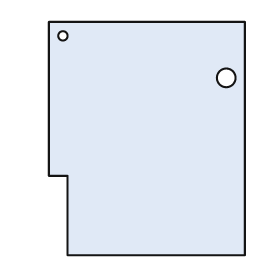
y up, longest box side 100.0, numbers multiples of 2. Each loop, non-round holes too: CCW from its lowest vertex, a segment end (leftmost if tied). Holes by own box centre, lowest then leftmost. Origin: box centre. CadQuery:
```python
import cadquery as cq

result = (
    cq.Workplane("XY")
    .moveTo(-34.0, -50.0)
    .lineTo(42.0, -50.0)
    .lineTo(42.0, 50.0)
    .lineTo(-42.0, 50.0)
    .lineTo(-42.0, -16.0)
    .lineTo(-34.0, -16.0)
    .close()
    .moveTo(34.0, 26.0)
    .circle(4.0)
    .moveTo(-36.0, 44.0)
    .circle(2.0)
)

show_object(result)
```